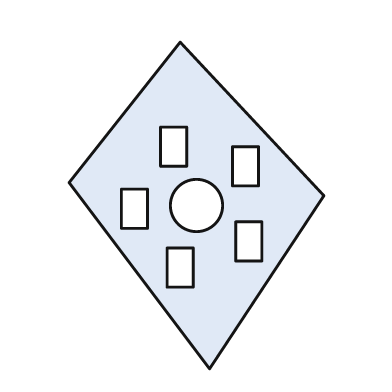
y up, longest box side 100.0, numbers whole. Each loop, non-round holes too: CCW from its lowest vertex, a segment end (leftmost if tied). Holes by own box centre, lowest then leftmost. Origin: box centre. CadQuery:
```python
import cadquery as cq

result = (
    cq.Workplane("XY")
    .moveTo(4.0, -50.0)
    .lineTo(39.0, 3.0)
    .lineTo(-5.0, 50.0)
    .lineTo(-39.0, 7.0)
    .close()
    .moveTo(-9.0, -25.0)
    .lineTo(-1.0, -25.0)
    .lineTo(-1.0, -13.0)
    .lineTo(-9.0, -13.0)
    .close()
    .moveTo(12.0, -17.0)
    .lineTo(20.0, -17.0)
    .lineTo(20.0, -5.0)
    .lineTo(12.0, -5.0)
    .close()
    .moveTo(-23.0, -7.0)
    .lineTo(-15.0, -7.0)
    .lineTo(-15.0, 5.0)
    .lineTo(-23.0, 5.0)
    .close()
    .moveTo(0.0, 0.0)
    .circle(8.0)
    .moveTo(11.0, 6.0)
    .lineTo(19.0, 6.0)
    .lineTo(19.0, 18.0)
    .lineTo(11.0, 18.0)
    .close()
    .moveTo(-11.0, 12.0)
    .lineTo(-3.0, 12.0)
    .lineTo(-3.0, 24.0)
    .lineTo(-11.0, 24.0)
    .close()
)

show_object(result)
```